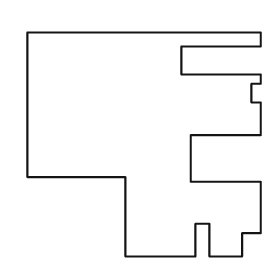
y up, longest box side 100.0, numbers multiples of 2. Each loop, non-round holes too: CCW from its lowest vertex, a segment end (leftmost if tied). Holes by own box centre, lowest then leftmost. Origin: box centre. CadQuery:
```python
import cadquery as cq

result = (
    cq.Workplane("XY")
    .moveTo(-8.0, -48.0)
    .lineTo(22.0, -48.0)
    .lineTo(22.0, -34.0)
    .lineTo(28.0, -34.0)
    .lineTo(28.0, -48.0)
    .lineTo(42.0, -48.0)
    .lineTo(42.0, -38.0)
    .lineTo(50.0, -38.0)
    .lineTo(50.0, -16.0)
    .lineTo(20.0, -16.0)
    .lineTo(20.0, 4.0)
    .lineTo(50.0, 4.0)
    .lineTo(50.0, 18.0)
    .lineTo(46.0, 18.0)
    .lineTo(46.0, 26.0)
    .lineTo(50.0, 26.0)
    .lineTo(50.0, 30.0)
    .lineTo(16.0, 30.0)
    .lineTo(16.0, 42.0)
    .lineTo(50.0, 42.0)
    .lineTo(50.0, 48.0)
    .lineTo(-50.0, 48.0)
    .lineTo(-50.0, -14.0)
    .lineTo(-8.0, -14.0)
    .close()
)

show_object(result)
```